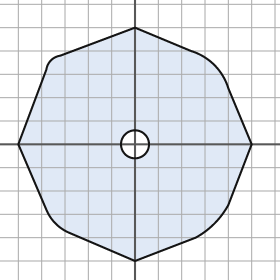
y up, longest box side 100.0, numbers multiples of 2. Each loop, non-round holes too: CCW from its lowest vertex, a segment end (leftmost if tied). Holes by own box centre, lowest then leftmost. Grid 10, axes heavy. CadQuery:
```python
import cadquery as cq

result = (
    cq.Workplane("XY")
    .moveTo(0.0, -50.0)
    .lineTo(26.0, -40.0)
    .threePointArc((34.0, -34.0), (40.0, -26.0))
    .lineTo(50.0, 0.0)
    .lineTo(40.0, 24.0)
    .threePointArc((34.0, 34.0), (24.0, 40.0))
    .lineTo(0.0, 50.0)
    .lineTo(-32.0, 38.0)
    .threePointArc((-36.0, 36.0), (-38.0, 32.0))
    .lineTo(-50.0, 0.0)
    .lineTo(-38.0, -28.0)
    .threePointArc((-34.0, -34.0), (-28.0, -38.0))
    .close()
    .moveTo(0.0, 0.0)
    .circle(6.0)
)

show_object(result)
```